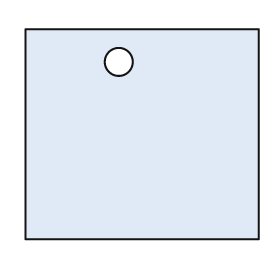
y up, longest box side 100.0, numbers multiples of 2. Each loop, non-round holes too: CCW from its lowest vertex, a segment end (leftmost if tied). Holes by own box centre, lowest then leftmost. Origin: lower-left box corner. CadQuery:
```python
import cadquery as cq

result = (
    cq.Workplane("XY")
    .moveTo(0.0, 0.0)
    .lineTo(100.0, 0.0)
    .lineTo(100.0, 90.0)
    .lineTo(0.0, 90.0)
    .close()
    .moveTo(40.0, 76.0)
    .circle(6.0)
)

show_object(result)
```